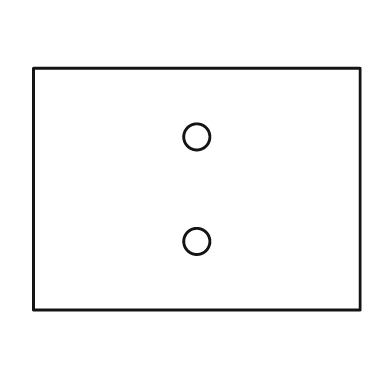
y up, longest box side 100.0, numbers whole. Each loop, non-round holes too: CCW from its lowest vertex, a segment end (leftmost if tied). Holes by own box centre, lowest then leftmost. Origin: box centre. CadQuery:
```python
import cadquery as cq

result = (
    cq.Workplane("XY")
    .moveTo(-50.0, -37.0)
    .lineTo(50.0, -37.0)
    .lineTo(50.0, 37.0)
    .lineTo(-50.0, 37.0)
    .close()
    .moveTo(0.0, -16.0)
    .circle(4.0)
    .moveTo(0.0, 16.0)
    .circle(4.0)
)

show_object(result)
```